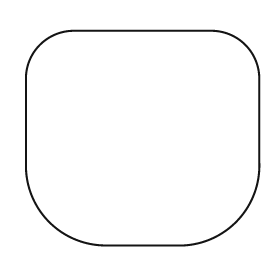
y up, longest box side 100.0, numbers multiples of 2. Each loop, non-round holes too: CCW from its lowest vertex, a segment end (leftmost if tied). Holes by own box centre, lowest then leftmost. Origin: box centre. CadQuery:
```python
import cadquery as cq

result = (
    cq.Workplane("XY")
    .moveTo(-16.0, -46.0)
    .lineTo(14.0, -46.0)
    .threePointArc((40.0, -36.0), (50.0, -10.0))
    .lineTo(50.0, 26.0)
    .threePointArc((44.0, 40.0), (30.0, 46.0))
    .lineTo(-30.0, 46.0)
    .threePointArc((-44.0, 40.0), (-50.0, 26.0))
    .lineTo(-50.0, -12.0)
    .threePointArc((-40.0, -36.0), (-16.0, -46.0))
    .close()
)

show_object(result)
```